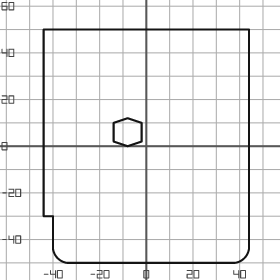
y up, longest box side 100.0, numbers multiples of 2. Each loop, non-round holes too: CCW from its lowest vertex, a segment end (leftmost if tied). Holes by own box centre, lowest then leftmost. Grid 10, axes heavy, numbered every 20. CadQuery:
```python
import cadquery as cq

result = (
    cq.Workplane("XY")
    .moveTo(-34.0, -50.0)
    .lineTo(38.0, -50.0)
    .threePointArc((42.0, -48.0), (44.0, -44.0))
    .lineTo(44.0, 50.0)
    .lineTo(-44.0, 50.0)
    .lineTo(-44.0, -30.0)
    .lineTo(-40.0, -30.0)
    .lineTo(-40.0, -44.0)
    .threePointArc((-38.0, -48.0), (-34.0, -50.0))
    .close()
    .moveTo(-8.0, 0.0)
    .lineTo(-2.0, 2.0)
    .lineTo(-2.0, 10.0)
    .lineTo(-8.0, 12.0)
    .lineTo(-14.0, 10.0)
    .lineTo(-14.0, 2.0)
    .close()
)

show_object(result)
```